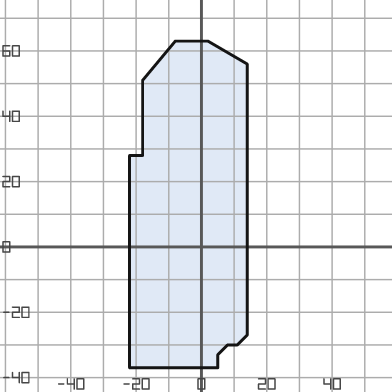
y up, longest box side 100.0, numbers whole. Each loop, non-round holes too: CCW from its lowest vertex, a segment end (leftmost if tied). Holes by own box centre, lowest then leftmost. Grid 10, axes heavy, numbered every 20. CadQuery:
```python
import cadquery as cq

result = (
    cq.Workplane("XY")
    .moveTo(-22.0, -37.0)
    .lineTo(5.0, -37.0)
    .lineTo(5.0, -33.0)
    .lineTo(8.0, -30.0)
    .lineTo(11.0, -30.0)
    .lineTo(14.0, -27.0)
    .lineTo(14.0, 56.0)
    .lineTo(2.0, 63.0)
    .lineTo(-8.0, 63.0)
    .lineTo(-18.0, 51.0)
    .lineTo(-18.0, 28.0)
    .lineTo(-22.0, 28.0)
    .close()
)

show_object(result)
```